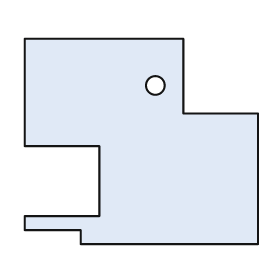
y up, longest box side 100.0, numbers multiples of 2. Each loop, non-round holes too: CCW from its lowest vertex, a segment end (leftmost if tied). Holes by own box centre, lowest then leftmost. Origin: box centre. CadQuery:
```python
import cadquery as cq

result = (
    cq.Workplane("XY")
    .moveTo(-26.0, -44.0)
    .lineTo(50.0, -44.0)
    .lineTo(50.0, 12.0)
    .lineTo(18.0, 12.0)
    .lineTo(18.0, 44.0)
    .lineTo(-50.0, 44.0)
    .lineTo(-50.0, -2.0)
    .lineTo(-18.0, -2.0)
    .lineTo(-18.0, -32.0)
    .lineTo(-50.0, -32.0)
    .lineTo(-50.0, -38.0)
    .lineTo(-26.0, -38.0)
    .close()
    .moveTo(6.0, 24.0)
    .circle(4.0)
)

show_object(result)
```